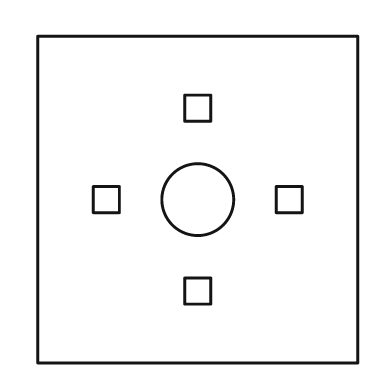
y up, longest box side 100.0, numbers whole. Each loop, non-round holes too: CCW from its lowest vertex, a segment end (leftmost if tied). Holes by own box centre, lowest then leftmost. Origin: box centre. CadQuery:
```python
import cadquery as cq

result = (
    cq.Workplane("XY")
    .moveTo(-49.0, -50.0)
    .lineTo(49.0, -50.0)
    .lineTo(49.0, 50.0)
    .lineTo(-49.0, 50.0)
    .close()
    .moveTo(-4.0, -32.0)
    .lineTo(4.0, -32.0)
    .lineTo(4.0, -24.0)
    .lineTo(-4.0, -24.0)
    .close()
    .moveTo(-32.0, -4.0)
    .lineTo(-24.0, -4.0)
    .lineTo(-24.0, 4.0)
    .lineTo(-32.0, 4.0)
    .close()
    .moveTo(0.0, 0.0)
    .circle(11.0)
    .moveTo(24.0, -4.0)
    .lineTo(32.0, -4.0)
    .lineTo(32.0, 4.0)
    .lineTo(24.0, 4.0)
    .close()
    .moveTo(-4.0, 24.0)
    .lineTo(4.0, 24.0)
    .lineTo(4.0, 32.0)
    .lineTo(-4.0, 32.0)
    .close()
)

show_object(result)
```